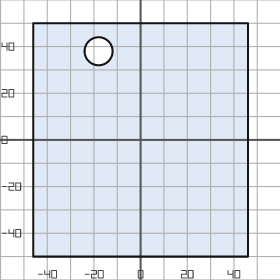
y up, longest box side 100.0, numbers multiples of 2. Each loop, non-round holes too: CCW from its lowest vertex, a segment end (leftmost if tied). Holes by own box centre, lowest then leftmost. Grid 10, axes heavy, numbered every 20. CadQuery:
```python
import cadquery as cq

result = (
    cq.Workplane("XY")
    .moveTo(-46.0, -50.0)
    .lineTo(46.0, -50.0)
    .lineTo(46.0, 50.0)
    .lineTo(-46.0, 50.0)
    .close()
    .moveTo(-18.0, 38.0)
    .circle(6.0)
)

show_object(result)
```